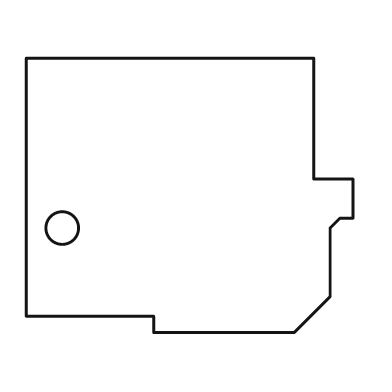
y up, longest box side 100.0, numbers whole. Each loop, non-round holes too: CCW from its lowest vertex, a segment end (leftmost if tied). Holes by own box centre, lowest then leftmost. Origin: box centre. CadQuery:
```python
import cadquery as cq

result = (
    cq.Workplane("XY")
    .moveTo(-11.0, -42.0)
    .lineTo(32.0, -42.0)
    .lineTo(43.0, -31.0)
    .lineTo(43.0, -10.0)
    .lineTo(46.0, -7.0)
    .lineTo(50.0, -7.0)
    .lineTo(50.0, 5.0)
    .lineTo(38.0, 5.0)
    .lineTo(38.0, 42.0)
    .lineTo(-50.0, 42.0)
    .lineTo(-50.0, -37.0)
    .lineTo(-11.0, -37.0)
    .close()
    .moveTo(-39.0, -10.0)
    .circle(5.0)
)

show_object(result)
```